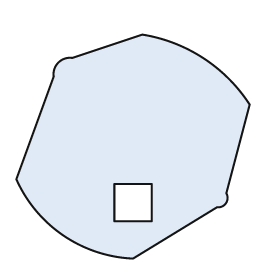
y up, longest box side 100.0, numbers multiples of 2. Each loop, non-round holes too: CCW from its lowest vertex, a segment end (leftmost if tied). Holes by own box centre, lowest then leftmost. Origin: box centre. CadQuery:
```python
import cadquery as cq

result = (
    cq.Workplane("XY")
    .moveTo(0.0, -48.0)
    .lineTo(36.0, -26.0)
    .threePointArc((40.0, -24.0), (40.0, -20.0))
    .lineTo(50.0, 18.0)
    .threePointArc((30.0, 38.0), (4.0, 48.0))
    .lineTo(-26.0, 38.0)
    .threePointArc((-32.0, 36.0), (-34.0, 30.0))
    .lineTo(-50.0, -14.0)
    .threePointArc((-30.0, -38.0), (0.0, -48.0))
    .close()
    .moveTo(-8.0, -32.0)
    .lineTo(8.0, -32.0)
    .lineTo(8.0, -16.0)
    .lineTo(-8.0, -16.0)
    .close()
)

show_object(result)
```